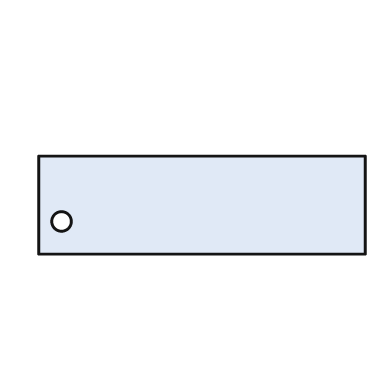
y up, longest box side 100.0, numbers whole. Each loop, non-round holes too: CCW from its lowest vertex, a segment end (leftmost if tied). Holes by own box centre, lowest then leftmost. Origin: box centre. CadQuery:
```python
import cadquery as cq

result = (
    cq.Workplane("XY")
    .moveTo(-50.0, -15.0)
    .lineTo(50.0, -15.0)
    .lineTo(50.0, 15.0)
    .lineTo(-50.0, 15.0)
    .close()
    .moveTo(-43.0, -5.0)
    .circle(3.0)
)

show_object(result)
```